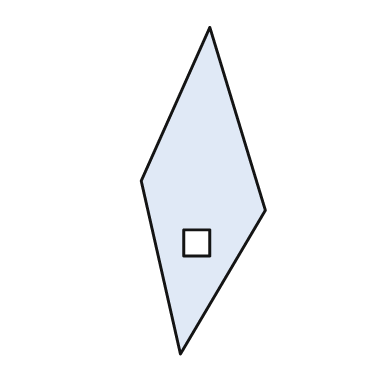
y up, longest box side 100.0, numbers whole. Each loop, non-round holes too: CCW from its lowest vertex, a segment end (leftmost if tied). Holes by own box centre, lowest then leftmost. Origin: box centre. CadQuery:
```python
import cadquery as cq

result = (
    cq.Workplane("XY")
    .moveTo(-7.0, -50.0)
    .lineTo(19.0, -6.0)
    .lineTo(2.0, 50.0)
    .lineTo(-19.0, 3.0)
    .close()
    .moveTo(-6.0, -20.0)
    .lineTo(2.0, -20.0)
    .lineTo(2.0, -12.0)
    .lineTo(-6.0, -12.0)
    .close()
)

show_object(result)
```